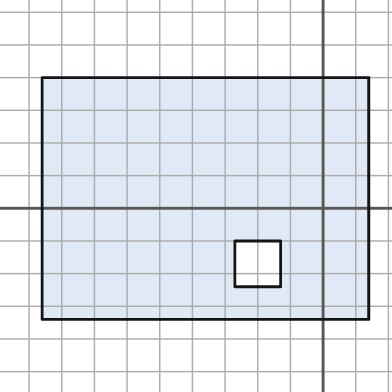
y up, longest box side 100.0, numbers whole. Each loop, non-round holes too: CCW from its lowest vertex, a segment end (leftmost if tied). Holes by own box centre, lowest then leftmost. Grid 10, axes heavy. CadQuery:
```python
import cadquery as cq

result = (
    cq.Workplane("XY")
    .moveTo(-86.0, -34.0)
    .lineTo(14.0, -34.0)
    .lineTo(14.0, 40.0)
    .lineTo(-86.0, 40.0)
    .close()
    .moveTo(-27.0, -24.0)
    .lineTo(-13.0, -24.0)
    .lineTo(-13.0, -10.0)
    .lineTo(-27.0, -10.0)
    .close()
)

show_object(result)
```